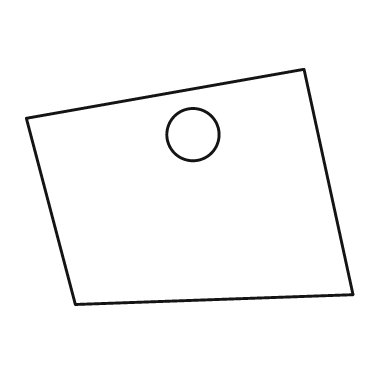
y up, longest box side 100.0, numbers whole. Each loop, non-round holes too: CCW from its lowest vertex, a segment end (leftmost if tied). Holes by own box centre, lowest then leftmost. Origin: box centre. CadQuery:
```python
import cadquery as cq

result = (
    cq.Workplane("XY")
    .moveTo(-35.0, -36.0)
    .lineTo(50.0, -33.0)
    .lineTo(35.0, 36.0)
    .lineTo(-50.0, 21.0)
    .close()
    .moveTo(1.0, 16.0)
    .circle(8.0)
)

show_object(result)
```